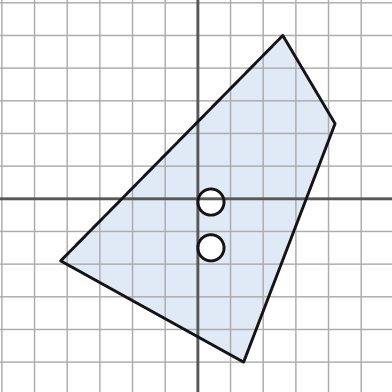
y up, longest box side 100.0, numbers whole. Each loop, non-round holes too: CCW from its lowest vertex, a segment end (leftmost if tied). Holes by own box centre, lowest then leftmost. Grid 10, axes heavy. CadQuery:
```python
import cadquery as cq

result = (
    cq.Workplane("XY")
    .moveTo(14.0, -50.0)
    .lineTo(42.0, 23.0)
    .lineTo(26.0, 50.0)
    .lineTo(-42.0, -19.0)
    .close()
    .moveTo(4.0, -15.0)
    .circle(4.0)
    .moveTo(4.0, -1.0)
    .circle(4.0)
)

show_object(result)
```